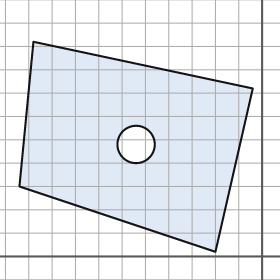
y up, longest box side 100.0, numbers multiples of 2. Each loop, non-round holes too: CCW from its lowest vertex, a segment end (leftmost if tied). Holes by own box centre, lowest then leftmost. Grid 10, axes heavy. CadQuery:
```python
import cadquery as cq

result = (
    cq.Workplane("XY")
    .moveTo(-20.0, 2.0)
    .lineTo(-4.0, 72.0)
    .lineTo(-98.0, 92.0)
    .lineTo(-104.0, 30.0)
    .close()
    .moveTo(-54.0, 48.0)
    .circle(8.0)
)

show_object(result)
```